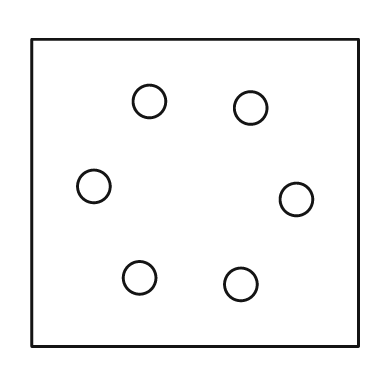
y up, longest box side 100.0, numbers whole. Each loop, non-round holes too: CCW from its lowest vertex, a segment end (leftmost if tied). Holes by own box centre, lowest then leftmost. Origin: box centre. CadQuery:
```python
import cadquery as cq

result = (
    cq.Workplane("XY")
    .moveTo(-50.0, -47.0)
    .lineTo(50.0, -47.0)
    .lineTo(50.0, 47.0)
    .lineTo(-50.0, 47.0)
    .close()
    .moveTo(14.0, -28.0)
    .circle(5.0)
    .moveTo(-17.0, -26.0)
    .circle(5.0)
    .moveTo(31.0, -2.0)
    .circle(5.0)
    .moveTo(-31.0, 2.0)
    .circle(5.0)
    .moveTo(17.0, 26.0)
    .circle(5.0)
    .moveTo(-14.0, 28.0)
    .circle(5.0)
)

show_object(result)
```